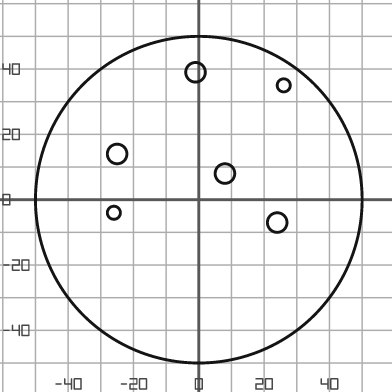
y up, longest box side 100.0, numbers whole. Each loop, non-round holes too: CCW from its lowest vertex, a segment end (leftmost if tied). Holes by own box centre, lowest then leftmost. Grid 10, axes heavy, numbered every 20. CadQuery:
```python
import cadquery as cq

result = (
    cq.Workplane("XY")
    .moveTo(0.0, 0.0)
    .circle(50.0)
    .moveTo(24.0, -7.0)
    .circle(3.0)
    .moveTo(-26.0, -4.0)
    .circle(2.0)
    .moveTo(8.0, 8.0)
    .circle(3.0)
    .moveTo(-25.0, 14.0)
    .circle(3.0)
    .moveTo(26.0, 35.0)
    .circle(2.0)
    .moveTo(-1.0, 39.0)
    .circle(3.0)
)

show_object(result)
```